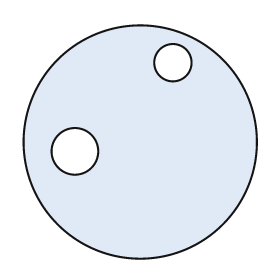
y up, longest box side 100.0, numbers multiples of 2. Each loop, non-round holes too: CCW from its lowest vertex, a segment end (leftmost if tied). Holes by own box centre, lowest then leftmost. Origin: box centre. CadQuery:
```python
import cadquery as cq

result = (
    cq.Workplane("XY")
    .moveTo(0.0, 0.0)
    .circle(50.0)
    .moveTo(-28.0, -4.0)
    .circle(10.0)
    .moveTo(14.0, 34.0)
    .circle(8.0)
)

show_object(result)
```